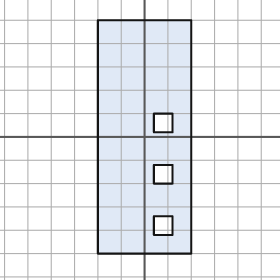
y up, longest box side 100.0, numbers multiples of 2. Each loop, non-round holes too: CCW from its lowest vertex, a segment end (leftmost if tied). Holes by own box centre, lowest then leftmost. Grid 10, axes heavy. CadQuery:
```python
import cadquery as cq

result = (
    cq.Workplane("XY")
    .moveTo(-20.0, -50.0)
    .lineTo(20.0, -50.0)
    .lineTo(20.0, 50.0)
    .lineTo(-20.0, 50.0)
    .close()
    .moveTo(4.0, -42.0)
    .lineTo(12.0, -42.0)
    .lineTo(12.0, -34.0)
    .lineTo(4.0, -34.0)
    .close()
    .moveTo(4.0, -20.0)
    .lineTo(12.0, -20.0)
    .lineTo(12.0, -12.0)
    .lineTo(4.0, -12.0)
    .close()
    .moveTo(4.0, 2.0)
    .lineTo(12.0, 2.0)
    .lineTo(12.0, 10.0)
    .lineTo(4.0, 10.0)
    .close()
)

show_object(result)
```